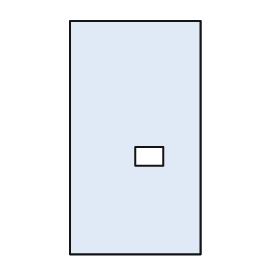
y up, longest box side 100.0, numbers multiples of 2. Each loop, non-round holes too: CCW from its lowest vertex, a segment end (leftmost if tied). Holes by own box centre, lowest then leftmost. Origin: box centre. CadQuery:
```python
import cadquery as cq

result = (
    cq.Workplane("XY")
    .moveTo(-28.0, -50.0)
    .lineTo(28.0, -50.0)
    .lineTo(28.0, 50.0)
    .lineTo(-28.0, 50.0)
    .close()
    .moveTo(0.0, -12.0)
    .lineTo(12.0, -12.0)
    .lineTo(12.0, -4.0)
    .lineTo(0.0, -4.0)
    .close()
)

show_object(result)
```